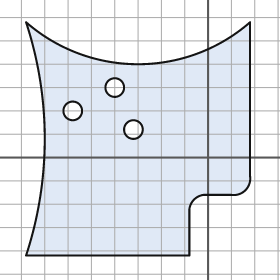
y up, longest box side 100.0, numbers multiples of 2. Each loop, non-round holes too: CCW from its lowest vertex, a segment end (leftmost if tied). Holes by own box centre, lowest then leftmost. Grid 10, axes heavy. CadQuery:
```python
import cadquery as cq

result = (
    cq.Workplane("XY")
    .moveTo(-78.0, -42.0)
    .lineTo(-8.0, -42.0)
    .lineTo(-8.0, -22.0)
    .threePointArc((-6.0, -18.0), (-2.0, -16.0))
    .lineTo(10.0, -16.0)
    .threePointArc((16.0, -14.0), (18.0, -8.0))
    .lineTo(18.0, 58.0)
    .threePointArc((-30.0, 40.0), (-78.0, 58.0))
    .threePointArc((-70.0, 8.0), (-78.0, -42.0))
    .close()
    .moveTo(-32.0, 12.0)
    .circle(4.0)
    .moveTo(-58.0, 20.0)
    .circle(4.0)
    .moveTo(-40.0, 30.0)
    .circle(4.0)
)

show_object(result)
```